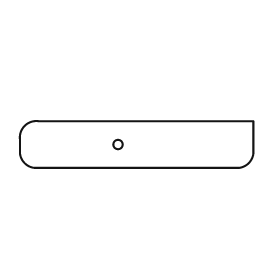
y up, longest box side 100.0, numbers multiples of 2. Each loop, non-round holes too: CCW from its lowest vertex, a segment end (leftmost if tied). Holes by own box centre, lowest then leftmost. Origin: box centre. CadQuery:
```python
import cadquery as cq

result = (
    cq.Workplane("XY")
    .moveTo(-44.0, -10.0)
    .lineTo(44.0, -10.0)
    .threePointArc((48.0, -8.0), (50.0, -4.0))
    .lineTo(50.0, 10.0)
    .lineTo(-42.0, 10.0)
    .threePointArc((-48.0, 8.0), (-50.0, 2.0))
    .lineTo(-50.0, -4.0)
    .threePointArc((-48.0, -8.0), (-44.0, -10.0))
    .close()
    .moveTo(-8.0, 0.0)
    .circle(2.0)
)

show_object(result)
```